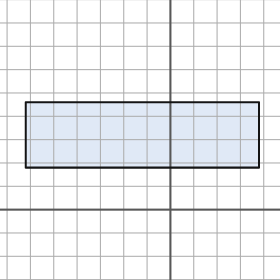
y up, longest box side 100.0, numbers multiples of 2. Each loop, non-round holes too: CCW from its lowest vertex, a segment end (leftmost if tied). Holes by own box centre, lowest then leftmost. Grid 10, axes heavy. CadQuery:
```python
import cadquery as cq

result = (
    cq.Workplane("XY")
    .moveTo(-62.0, 18.0)
    .lineTo(38.0, 18.0)
    .lineTo(38.0, 46.0)
    .lineTo(-62.0, 46.0)
    .close()
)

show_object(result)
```